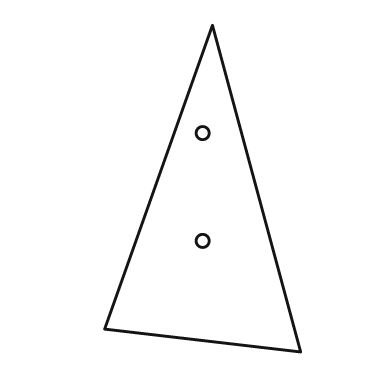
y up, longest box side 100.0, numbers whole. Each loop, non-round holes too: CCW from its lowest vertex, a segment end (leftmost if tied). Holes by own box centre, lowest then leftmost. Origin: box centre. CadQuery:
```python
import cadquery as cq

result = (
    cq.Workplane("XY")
    .moveTo(30.0, -50.0)
    .lineTo(3.0, 50.0)
    .lineTo(-30.0, -43.0)
    .close()
    .moveTo(0.0, -16.0)
    .circle(2.0)
    .moveTo(0.0, 17.0)
    .circle(2.0)
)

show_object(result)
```